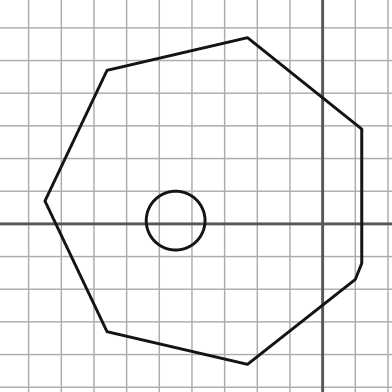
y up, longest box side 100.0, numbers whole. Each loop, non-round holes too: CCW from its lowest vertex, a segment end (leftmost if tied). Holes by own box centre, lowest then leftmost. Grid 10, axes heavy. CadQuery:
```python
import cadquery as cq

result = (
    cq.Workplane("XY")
    .moveTo(-23.0, -43.0)
    .lineTo(10.0, -17.0)
    .lineTo(12.0, -12.0)
    .lineTo(12.0, 29.0)
    .lineTo(-23.0, 57.0)
    .lineTo(-66.0, 47.0)
    .lineTo(-85.0, 7.0)
    .lineTo(-66.0, -33.0)
    .close()
    .moveTo(-45.0, 1.0)
    .circle(9.0)
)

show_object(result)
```